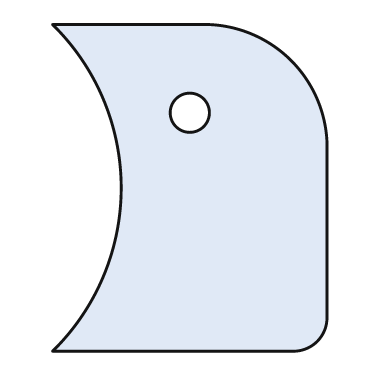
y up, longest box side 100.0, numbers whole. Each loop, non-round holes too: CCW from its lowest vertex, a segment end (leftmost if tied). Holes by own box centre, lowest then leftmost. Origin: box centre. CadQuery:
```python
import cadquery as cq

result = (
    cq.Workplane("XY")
    .moveTo(-42.0, -50.0)
    .lineTo(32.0, -50.0)
    .threePointArc((39.0, -47.0), (42.0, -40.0))
    .lineTo(42.0, 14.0)
    .threePointArc((31.0, 39.0), (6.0, 50.0))
    .lineTo(-42.0, 50.0)
    .threePointArc((-21.0, 0.0), (-42.0, -50.0))
    .close()
    .moveTo(0.0, 23.0)
    .circle(6.0)
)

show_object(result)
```